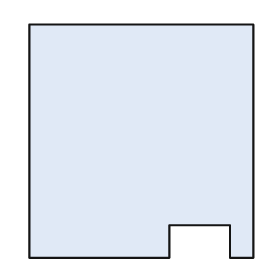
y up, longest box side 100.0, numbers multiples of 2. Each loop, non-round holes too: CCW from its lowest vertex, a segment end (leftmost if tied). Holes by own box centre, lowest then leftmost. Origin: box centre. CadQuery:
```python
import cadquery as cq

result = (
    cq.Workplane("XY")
    .moveTo(-48.0, -50.0)
    .lineTo(12.0, -50.0)
    .lineTo(12.0, -36.0)
    .lineTo(38.0, -36.0)
    .lineTo(38.0, -50.0)
    .lineTo(48.0, -50.0)
    .lineTo(48.0, 50.0)
    .lineTo(-48.0, 50.0)
    .close()
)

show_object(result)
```